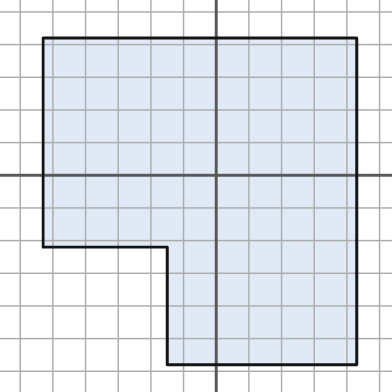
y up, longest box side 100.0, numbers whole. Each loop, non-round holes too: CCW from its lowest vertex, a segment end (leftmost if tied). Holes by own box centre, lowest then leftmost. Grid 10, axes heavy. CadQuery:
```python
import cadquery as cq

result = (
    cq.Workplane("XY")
    .moveTo(-15.0, -58.0)
    .lineTo(43.0, -58.0)
    .lineTo(43.0, 42.0)
    .lineTo(-53.0, 42.0)
    .lineTo(-53.0, -22.0)
    .lineTo(-15.0, -22.0)
    .close()
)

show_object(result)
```